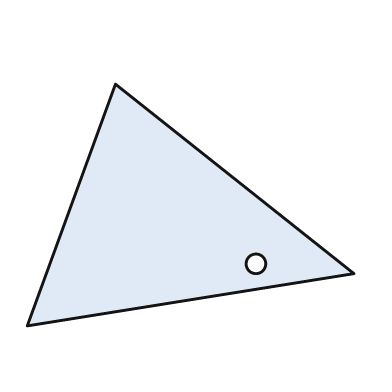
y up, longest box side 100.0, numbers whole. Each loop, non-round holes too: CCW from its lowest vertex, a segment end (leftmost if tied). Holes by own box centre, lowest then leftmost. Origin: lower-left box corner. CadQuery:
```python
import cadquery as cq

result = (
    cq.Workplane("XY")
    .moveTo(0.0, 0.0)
    .lineTo(100.0, 16.0)
    .lineTo(27.0, 74.0)
    .close()
    .moveTo(70.0, 19.0)
    .circle(3.0)
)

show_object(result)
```